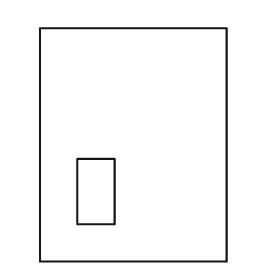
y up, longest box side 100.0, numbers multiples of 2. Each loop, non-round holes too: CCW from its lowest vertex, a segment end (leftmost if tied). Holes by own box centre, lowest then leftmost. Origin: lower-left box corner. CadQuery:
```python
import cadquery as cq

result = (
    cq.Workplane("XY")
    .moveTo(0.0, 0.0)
    .lineTo(80.0, 0.0)
    .lineTo(80.0, 100.0)
    .lineTo(0.0, 100.0)
    .close()
    .moveTo(16.0, 16.0)
    .lineTo(32.0, 16.0)
    .lineTo(32.0, 44.0)
    .lineTo(16.0, 44.0)
    .close()
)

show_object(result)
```